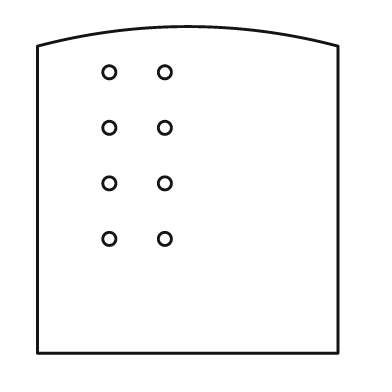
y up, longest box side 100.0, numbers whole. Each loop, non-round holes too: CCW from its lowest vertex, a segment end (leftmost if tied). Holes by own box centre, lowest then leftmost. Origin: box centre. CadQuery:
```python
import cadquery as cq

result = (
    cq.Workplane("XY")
    .moveTo(-46.0, -50.0)
    .lineTo(46.0, -50.0)
    .lineTo(46.0, 44.0)
    .threePointArc((0.0, 50.0), (-46.0, 44.0))
    .close()
    .moveTo(-24.0, -15.0)
    .circle(2.0)
    .moveTo(-7.0, -15.0)
    .circle(2.0)
    .moveTo(-24.0, 2.0)
    .circle(2.0)
    .moveTo(-7.0, 2.0)
    .circle(2.0)
    .moveTo(-24.0, 19.0)
    .circle(2.0)
    .moveTo(-7.0, 19.0)
    .circle(2.0)
    .moveTo(-24.0, 36.0)
    .circle(2.0)
    .moveTo(-7.0, 36.0)
    .circle(2.0)
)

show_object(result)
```